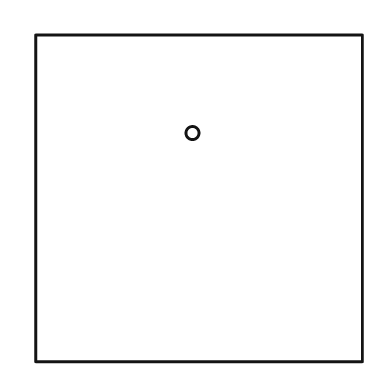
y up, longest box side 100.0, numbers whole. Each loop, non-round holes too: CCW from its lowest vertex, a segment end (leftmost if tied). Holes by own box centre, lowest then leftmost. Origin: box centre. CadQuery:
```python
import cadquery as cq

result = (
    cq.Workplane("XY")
    .moveTo(-50.0, -50.0)
    .lineTo(50.0, -50.0)
    .lineTo(50.0, 50.0)
    .lineTo(-50.0, 50.0)
    .close()
    .moveTo(-2.0, 20.0)
    .circle(2.0)
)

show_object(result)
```